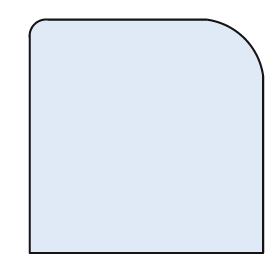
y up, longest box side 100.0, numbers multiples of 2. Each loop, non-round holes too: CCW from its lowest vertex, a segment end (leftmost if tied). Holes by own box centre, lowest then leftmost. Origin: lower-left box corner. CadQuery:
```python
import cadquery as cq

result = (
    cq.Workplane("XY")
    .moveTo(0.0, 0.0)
    .lineTo(100.0, 0.0)
    .lineTo(100.0, 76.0)
    .threePointArc((92.0, 92.0), (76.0, 100.0))
    .lineTo(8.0, 100.0)
    .threePointArc((2.0, 98.0), (0.0, 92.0))
    .close()
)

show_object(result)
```